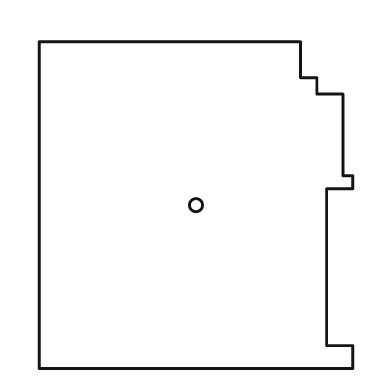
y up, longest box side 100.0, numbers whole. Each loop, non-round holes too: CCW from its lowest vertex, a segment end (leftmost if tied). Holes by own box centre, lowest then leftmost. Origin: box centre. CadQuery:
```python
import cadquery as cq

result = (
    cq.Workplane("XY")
    .moveTo(-48.0, -50.0)
    .lineTo(48.0, -50.0)
    .lineTo(48.0, -43.0)
    .lineTo(40.0, -43.0)
    .lineTo(40.0, 5.0)
    .lineTo(48.0, 5.0)
    .lineTo(48.0, 9.0)
    .lineTo(45.0, 9.0)
    .lineTo(45.0, 34.0)
    .lineTo(37.0, 34.0)
    .lineTo(37.0, 39.0)
    .lineTo(32.0, 39.0)
    .lineTo(32.0, 50.0)
    .lineTo(-48.0, 50.0)
    .close()
    .moveTo(0.0, 0.0)
    .circle(2.0)
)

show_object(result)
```